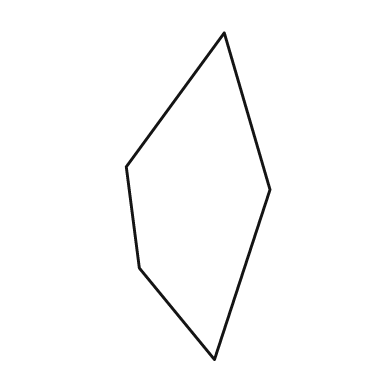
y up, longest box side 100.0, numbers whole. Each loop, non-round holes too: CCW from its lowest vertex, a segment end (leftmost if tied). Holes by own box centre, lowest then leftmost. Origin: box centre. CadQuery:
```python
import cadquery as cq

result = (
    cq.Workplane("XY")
    .moveTo(5.0, -50.0)
    .lineTo(22.0, 2.0)
    .lineTo(8.0, 50.0)
    .lineTo(-22.0, 9.0)
    .lineTo(-18.0, -22.0)
    .close()
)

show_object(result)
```